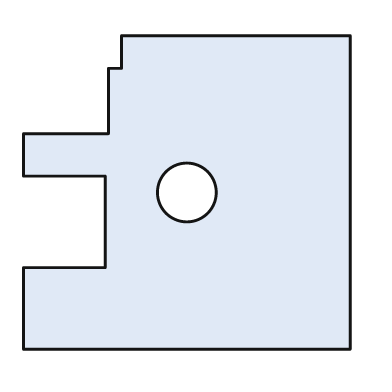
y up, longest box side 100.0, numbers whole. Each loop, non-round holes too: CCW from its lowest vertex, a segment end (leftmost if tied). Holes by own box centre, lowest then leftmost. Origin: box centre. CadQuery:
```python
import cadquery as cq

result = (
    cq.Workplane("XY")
    .moveTo(-50.0, -48.0)
    .lineTo(50.0, -48.0)
    .lineTo(50.0, 48.0)
    .lineTo(-20.0, 48.0)
    .lineTo(-20.0, 38.0)
    .lineTo(-24.0, 38.0)
    .lineTo(-24.0, 18.0)
    .lineTo(-50.0, 18.0)
    .lineTo(-50.0, 5.0)
    .lineTo(-25.0, 5.0)
    .lineTo(-25.0, -23.0)
    .lineTo(-50.0, -23.0)
    .close()
    .moveTo(0.0, 0.0)
    .circle(9.0)
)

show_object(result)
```